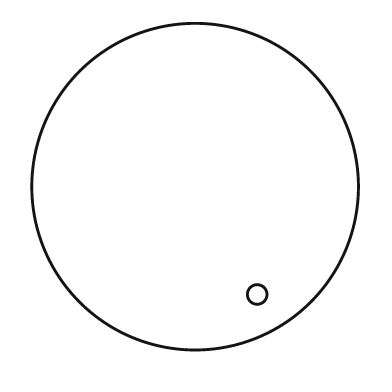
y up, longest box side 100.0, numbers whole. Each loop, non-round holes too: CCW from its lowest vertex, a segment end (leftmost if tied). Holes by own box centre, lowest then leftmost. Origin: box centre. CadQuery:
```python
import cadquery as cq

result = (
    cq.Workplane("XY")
    .moveTo(0.0, 0.0)
    .circle(50.0)
    .moveTo(19.0, -33.0)
    .circle(3.0)
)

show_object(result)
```